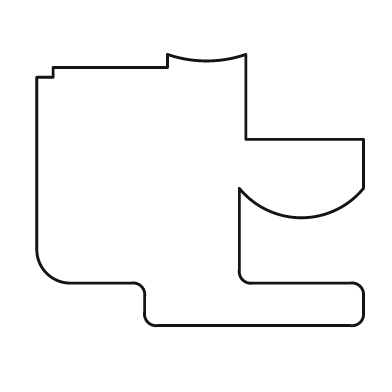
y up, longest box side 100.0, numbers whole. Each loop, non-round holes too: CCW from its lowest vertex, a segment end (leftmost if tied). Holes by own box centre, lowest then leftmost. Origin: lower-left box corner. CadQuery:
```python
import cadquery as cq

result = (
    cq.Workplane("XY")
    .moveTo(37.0, 0.0)
    .lineTo(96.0, 0.0)
    .threePointArc((99.0, 1.0), (100.0, 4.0))
    .lineTo(100.0, 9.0)
    .threePointArc((99.0, 12.0), (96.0, 13.0))
    .lineTo(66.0, 13.0)
    .threePointArc((63.0, 14.0), (62.0, 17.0))
    .lineTo(62.0, 42.0)
    .threePointArc((81.0, 33.0), (100.0, 42.0))
    .lineTo(100.0, 57.0)
    .lineTo(64.0, 57.0)
    .lineTo(64.0, 83.0)
    .threePointArc((52.0, 81.0), (40.0, 83.0))
    .lineTo(40.0, 79.0)
    .lineTo(5.0, 79.0)
    .lineTo(5.0, 76.0)
    .lineTo(0.0, 76.0)
    .lineTo(0.0, 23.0)
    .threePointArc((3.0, 16.0), (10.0, 13.0))
    .lineTo(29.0, 13.0)
    .threePointArc((32.0, 12.0), (33.0, 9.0))
    .lineTo(33.0, 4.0)
    .threePointArc((34.0, 1.0), (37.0, 0.0))
    .close()
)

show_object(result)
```